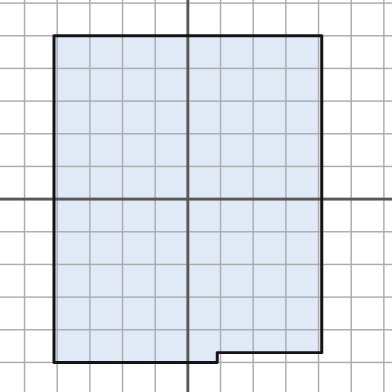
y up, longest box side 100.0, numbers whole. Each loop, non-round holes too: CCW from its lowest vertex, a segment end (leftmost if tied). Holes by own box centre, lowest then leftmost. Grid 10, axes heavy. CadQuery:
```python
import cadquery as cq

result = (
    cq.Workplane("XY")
    .moveTo(-41.0, -50.0)
    .lineTo(9.0, -50.0)
    .lineTo(9.0, -47.0)
    .lineTo(41.0, -47.0)
    .lineTo(41.0, 50.0)
    .lineTo(-41.0, 50.0)
    .close()
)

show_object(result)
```